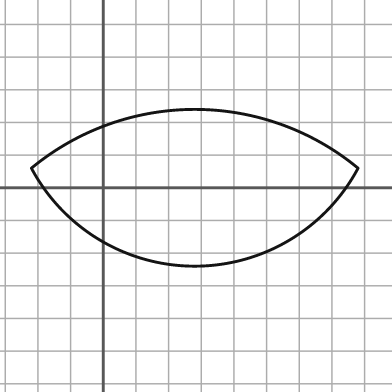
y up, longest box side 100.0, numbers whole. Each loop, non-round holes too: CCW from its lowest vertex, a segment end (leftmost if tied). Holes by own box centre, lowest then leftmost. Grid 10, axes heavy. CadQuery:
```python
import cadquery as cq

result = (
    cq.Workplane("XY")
    .moveTo(-22.0, 6.0)
    .threePointArc((28.0, -24.0), (78.0, 6.0))
    .threePointArc((28.0, 24.0), (-22.0, 6.0))
    .close()
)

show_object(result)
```